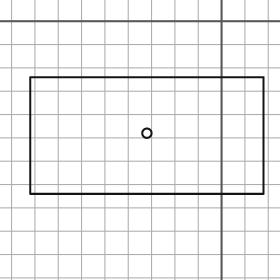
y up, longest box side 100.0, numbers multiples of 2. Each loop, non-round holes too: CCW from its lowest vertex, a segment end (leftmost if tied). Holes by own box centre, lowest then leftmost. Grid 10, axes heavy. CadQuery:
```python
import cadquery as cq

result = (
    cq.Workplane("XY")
    .moveTo(-82.0, -74.0)
    .lineTo(18.0, -74.0)
    .lineTo(18.0, -24.0)
    .lineTo(-82.0, -24.0)
    .close()
    .moveTo(-32.0, -48.0)
    .circle(2.0)
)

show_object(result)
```